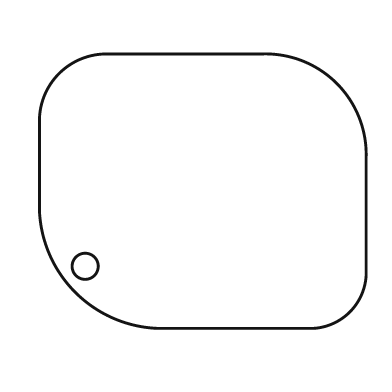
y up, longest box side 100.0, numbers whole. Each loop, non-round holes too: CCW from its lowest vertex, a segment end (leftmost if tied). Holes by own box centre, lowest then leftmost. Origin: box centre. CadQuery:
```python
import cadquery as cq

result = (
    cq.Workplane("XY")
    .moveTo(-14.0, -42.0)
    .lineTo(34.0, -42.0)
    .threePointArc((45.0, -37.0), (50.0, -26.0))
    .lineTo(50.0, 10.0)
    .threePointArc((41.0, 33.0), (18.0, 42.0))
    .lineTo(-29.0, 42.0)
    .threePointArc((-44.0, 36.0), (-50.0, 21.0))
    .lineTo(-50.0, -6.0)
    .threePointArc((-39.0, -31.0), (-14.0, -42.0))
    .close()
    .moveTo(-36.0, -23.0)
    .circle(4.0)
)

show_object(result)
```